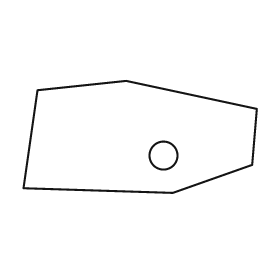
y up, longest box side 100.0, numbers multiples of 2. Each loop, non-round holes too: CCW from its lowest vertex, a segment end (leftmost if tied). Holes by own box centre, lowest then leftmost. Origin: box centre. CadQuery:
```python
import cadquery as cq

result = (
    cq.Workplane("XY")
    .moveTo(14.0, -24.0)
    .lineTo(48.0, -12.0)
    .lineTo(50.0, 12.0)
    .lineTo(-6.0, 24.0)
    .lineTo(-44.0, 20.0)
    .lineTo(-50.0, -22.0)
    .close()
    .moveTo(10.0, -8.0)
    .circle(6.0)
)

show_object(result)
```